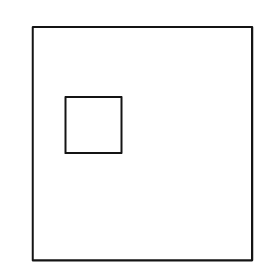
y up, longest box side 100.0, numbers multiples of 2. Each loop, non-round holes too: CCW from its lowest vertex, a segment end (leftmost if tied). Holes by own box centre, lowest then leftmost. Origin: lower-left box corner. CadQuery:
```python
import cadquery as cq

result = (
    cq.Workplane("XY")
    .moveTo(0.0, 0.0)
    .lineTo(94.0, 0.0)
    .lineTo(94.0, 100.0)
    .lineTo(0.0, 100.0)
    .close()
    .moveTo(14.0, 46.0)
    .lineTo(38.0, 46.0)
    .lineTo(38.0, 70.0)
    .lineTo(14.0, 70.0)
    .close()
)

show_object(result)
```